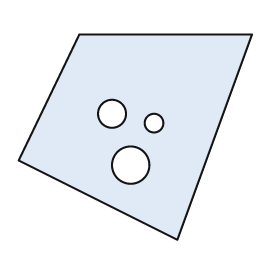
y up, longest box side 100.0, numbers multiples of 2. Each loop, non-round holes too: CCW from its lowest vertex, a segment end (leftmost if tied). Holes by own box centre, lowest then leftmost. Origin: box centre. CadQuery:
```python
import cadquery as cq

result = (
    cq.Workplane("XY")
    .moveTo(18.0, -44.0)
    .lineTo(50.0, 44.0)
    .lineTo(-24.0, 44.0)
    .lineTo(-50.0, -10.0)
    .close()
    .moveTo(-2.0, -12.0)
    .circle(8.0)
    .moveTo(8.0, 6.0)
    .circle(4.0)
    .moveTo(-10.0, 10.0)
    .circle(6.0)
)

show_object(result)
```